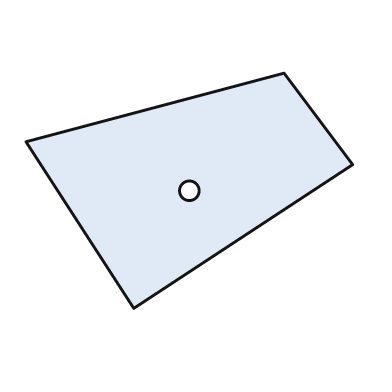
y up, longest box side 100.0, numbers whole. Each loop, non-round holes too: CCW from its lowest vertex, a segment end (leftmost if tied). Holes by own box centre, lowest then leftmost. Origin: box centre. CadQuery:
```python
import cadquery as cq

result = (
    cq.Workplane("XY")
    .moveTo(-17.0, -36.0)
    .lineTo(50.0, 8.0)
    .lineTo(29.0, 36.0)
    .lineTo(-50.0, 15.0)
    .close()
    .moveTo(0.0, 0.0)
    .circle(3.0)
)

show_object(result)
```